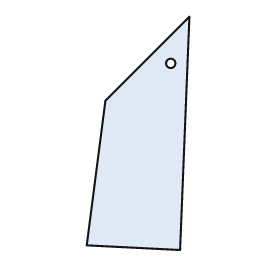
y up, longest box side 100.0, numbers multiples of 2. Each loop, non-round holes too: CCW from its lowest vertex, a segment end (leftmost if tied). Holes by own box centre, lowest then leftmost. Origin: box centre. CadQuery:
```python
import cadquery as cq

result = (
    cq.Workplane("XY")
    .moveTo(18.0, -50.0)
    .lineTo(22.0, 50.0)
    .lineTo(-14.0, 14.0)
    .lineTo(-22.0, -48.0)
    .close()
    .moveTo(14.0, 30.0)
    .circle(2.0)
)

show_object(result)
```